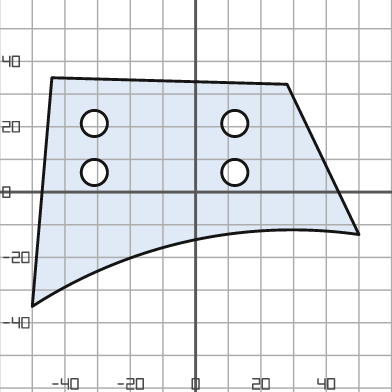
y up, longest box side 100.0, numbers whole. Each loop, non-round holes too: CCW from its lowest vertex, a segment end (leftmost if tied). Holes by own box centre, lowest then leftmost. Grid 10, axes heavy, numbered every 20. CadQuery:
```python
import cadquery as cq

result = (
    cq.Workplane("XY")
    .moveTo(-50.0, -35.0)
    .threePointArc((-2.0, -15.0), (50.0, -13.0))
    .lineTo(28.0, 33.0)
    .lineTo(-44.0, 35.0)
    .close()
    .moveTo(-31.0, 6.0)
    .circle(4.0)
    .moveTo(12.0, 6.0)
    .circle(4.0)
    .moveTo(-31.0, 21.0)
    .circle(4.0)
    .moveTo(12.0, 21.0)
    .circle(4.0)
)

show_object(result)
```